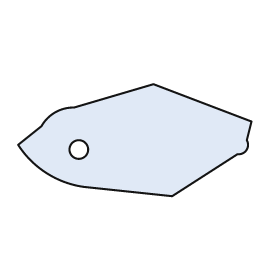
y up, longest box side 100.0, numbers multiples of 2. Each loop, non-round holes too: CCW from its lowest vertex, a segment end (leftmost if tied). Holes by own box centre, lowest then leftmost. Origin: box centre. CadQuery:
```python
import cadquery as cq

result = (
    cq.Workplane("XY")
    .moveTo(16.0, -24.0)
    .lineTo(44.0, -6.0)
    .threePointArc((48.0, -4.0), (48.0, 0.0))
    .lineTo(50.0, 8.0)
    .lineTo(8.0, 24.0)
    .lineTo(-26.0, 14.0)
    .threePointArc((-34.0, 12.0), (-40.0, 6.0))
    .lineTo(-50.0, -2.0)
    .threePointArc((-38.0, -14.0), (-22.0, -20.0))
    .close()
    .moveTo(-24.0, -4.0)
    .circle(4.0)
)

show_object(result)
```